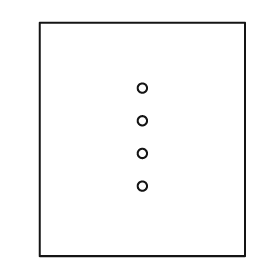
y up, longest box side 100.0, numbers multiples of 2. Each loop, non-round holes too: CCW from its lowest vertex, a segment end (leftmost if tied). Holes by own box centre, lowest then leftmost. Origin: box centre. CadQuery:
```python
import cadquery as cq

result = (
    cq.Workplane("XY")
    .moveTo(-44.0, -50.0)
    .lineTo(44.0, -50.0)
    .lineTo(44.0, 50.0)
    .lineTo(-44.0, 50.0)
    .close()
    .moveTo(0.0, -20.0)
    .circle(2.0)
    .moveTo(0.0, -6.0)
    .circle(2.0)
    .moveTo(0.0, 8.0)
    .circle(2.0)
    .moveTo(0.0, 22.0)
    .circle(2.0)
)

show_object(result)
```